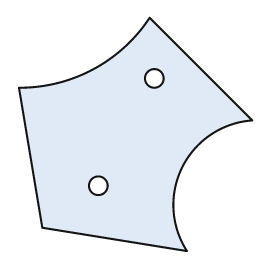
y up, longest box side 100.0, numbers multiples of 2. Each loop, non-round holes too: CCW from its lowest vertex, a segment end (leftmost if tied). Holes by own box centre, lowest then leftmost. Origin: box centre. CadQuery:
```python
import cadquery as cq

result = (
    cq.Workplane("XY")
    .moveTo(22.0, -50.0)
    .threePointArc((20.0, -14.0), (50.0, 6.0))
    .lineTo(6.0, 50.0)
    .threePointArc((-18.0, 28.0), (-50.0, 20.0))
    .lineTo(-40.0, -40.0)
    .close()
    .moveTo(-16.0, -22.0)
    .circle(4.0)
    .moveTo(8.0, 24.0)
    .circle(4.0)
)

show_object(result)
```